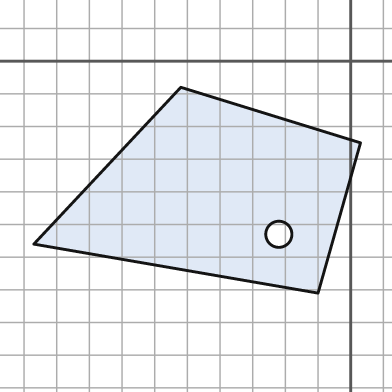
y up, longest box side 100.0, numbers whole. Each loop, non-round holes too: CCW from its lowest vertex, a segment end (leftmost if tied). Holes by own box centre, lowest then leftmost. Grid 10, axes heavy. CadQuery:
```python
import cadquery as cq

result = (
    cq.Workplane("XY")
    .moveTo(-10.0, -71.0)
    .lineTo(3.0, -25.0)
    .lineTo(-52.0, -8.0)
    .lineTo(-97.0, -56.0)
    .close()
    .moveTo(-22.0, -53.0)
    .circle(4.0)
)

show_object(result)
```